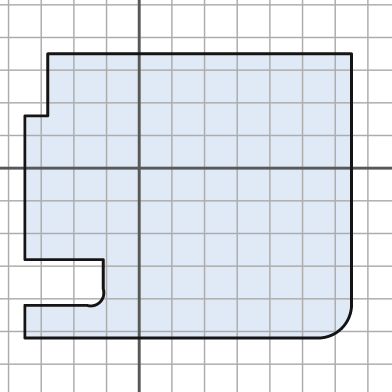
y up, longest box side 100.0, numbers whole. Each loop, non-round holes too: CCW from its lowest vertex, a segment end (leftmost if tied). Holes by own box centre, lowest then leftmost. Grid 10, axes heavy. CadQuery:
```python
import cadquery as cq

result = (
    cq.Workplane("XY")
    .moveTo(-35.0, -52.0)
    .lineTo(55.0, -52.0)
    .threePointArc((62.0, -49.0), (65.0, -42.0))
    .lineTo(65.0, 35.0)
    .lineTo(-28.0, 35.0)
    .lineTo(-28.0, 16.0)
    .lineTo(-35.0, 16.0)
    .lineTo(-35.0, -28.0)
    .lineTo(-11.0, -28.0)
    .lineTo(-11.0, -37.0)
    .threePointArc((-12.0, -41.0), (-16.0, -42.0))
    .lineTo(-35.0, -42.0)
    .close()
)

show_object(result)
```